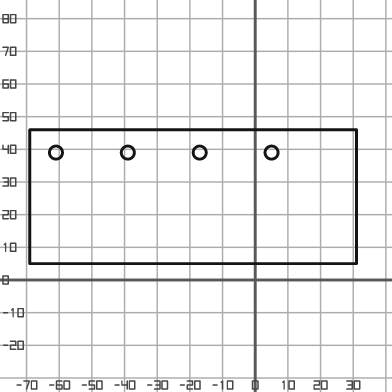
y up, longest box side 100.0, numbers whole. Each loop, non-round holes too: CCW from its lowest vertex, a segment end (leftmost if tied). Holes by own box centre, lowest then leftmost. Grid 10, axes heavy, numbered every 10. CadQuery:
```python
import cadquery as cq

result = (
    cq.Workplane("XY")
    .moveTo(-69.0, 5.0)
    .lineTo(31.0, 5.0)
    .lineTo(31.0, 46.0)
    .lineTo(-69.0, 46.0)
    .close()
    .moveTo(-61.0, 39.0)
    .circle(2.0)
    .moveTo(-39.0, 39.0)
    .circle(2.0)
    .moveTo(-17.0, 39.0)
    .circle(2.0)
    .moveTo(5.0, 39.0)
    .circle(2.0)
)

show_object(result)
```